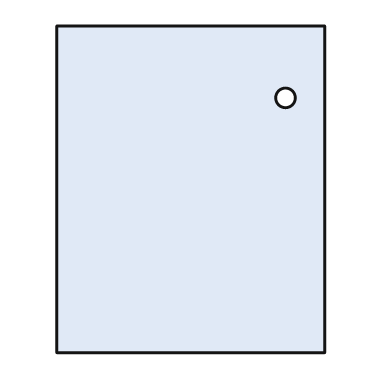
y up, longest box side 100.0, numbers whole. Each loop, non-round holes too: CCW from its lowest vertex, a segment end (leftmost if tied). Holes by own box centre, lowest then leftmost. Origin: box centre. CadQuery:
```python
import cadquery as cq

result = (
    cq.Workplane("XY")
    .moveTo(-41.0, -50.0)
    .lineTo(41.0, -50.0)
    .lineTo(41.0, 50.0)
    .lineTo(-41.0, 50.0)
    .close()
    .moveTo(29.0, 28.0)
    .circle(3.0)
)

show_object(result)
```